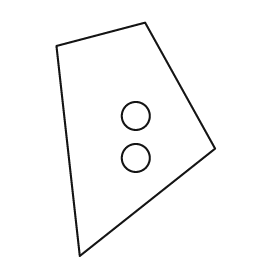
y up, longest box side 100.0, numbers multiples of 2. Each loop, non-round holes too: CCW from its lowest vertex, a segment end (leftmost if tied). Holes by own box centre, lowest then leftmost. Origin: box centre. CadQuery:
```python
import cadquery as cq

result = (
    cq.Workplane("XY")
    .moveTo(-24.0, -50.0)
    .lineTo(34.0, -4.0)
    .lineTo(4.0, 50.0)
    .lineTo(-34.0, 40.0)
    .close()
    .moveTo(0.0, -8.0)
    .circle(6.0)
    .moveTo(0.0, 10.0)
    .circle(6.0)
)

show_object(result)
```